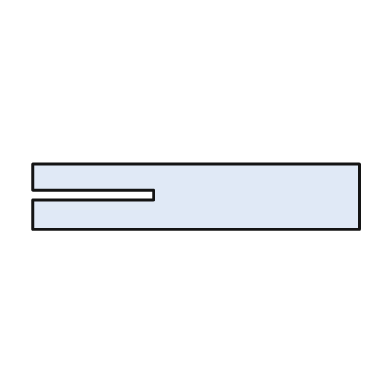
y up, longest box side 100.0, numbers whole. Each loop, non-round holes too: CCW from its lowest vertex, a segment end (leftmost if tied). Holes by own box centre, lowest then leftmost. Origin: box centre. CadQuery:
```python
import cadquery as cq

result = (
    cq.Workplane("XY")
    .moveTo(-50.0, -10.0)
    .lineTo(50.0, -10.0)
    .lineTo(50.0, 10.0)
    .lineTo(-50.0, 10.0)
    .lineTo(-50.0, 2.0)
    .lineTo(-13.0, 2.0)
    .lineTo(-13.0, -1.0)
    .lineTo(-50.0, -1.0)
    .close()
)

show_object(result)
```